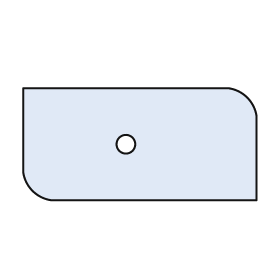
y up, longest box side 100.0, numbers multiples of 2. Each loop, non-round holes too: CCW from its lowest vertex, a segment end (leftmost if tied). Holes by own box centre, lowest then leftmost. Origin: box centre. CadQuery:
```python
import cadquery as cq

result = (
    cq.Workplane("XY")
    .moveTo(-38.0, -24.0)
    .lineTo(50.0, -24.0)
    .lineTo(50.0, 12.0)
    .threePointArc((46.0, 20.0), (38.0, 24.0))
    .lineTo(-50.0, 24.0)
    .lineTo(-50.0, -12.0)
    .threePointArc((-46.0, -20.0), (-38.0, -24.0))
    .close()
    .moveTo(-6.0, 0.0)
    .circle(4.0)
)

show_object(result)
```